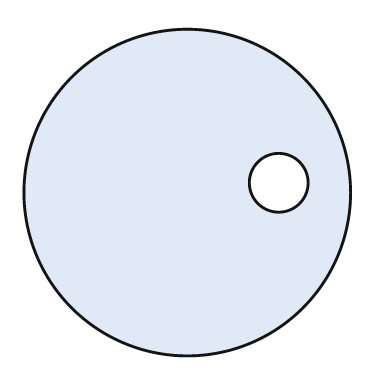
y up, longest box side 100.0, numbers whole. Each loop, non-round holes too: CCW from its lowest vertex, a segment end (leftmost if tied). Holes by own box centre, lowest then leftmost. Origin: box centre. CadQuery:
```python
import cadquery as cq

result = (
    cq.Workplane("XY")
    .moveTo(0.0, 0.0)
    .circle(50.0)
    .moveTo(28.0, 3.0)
    .circle(9.0)
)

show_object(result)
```